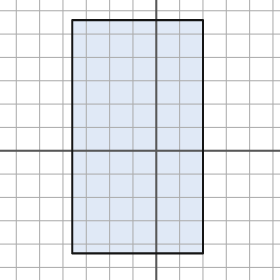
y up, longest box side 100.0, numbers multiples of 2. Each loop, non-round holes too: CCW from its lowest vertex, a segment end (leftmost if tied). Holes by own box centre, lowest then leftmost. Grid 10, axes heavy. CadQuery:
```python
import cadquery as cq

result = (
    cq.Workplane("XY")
    .moveTo(-36.0, -44.0)
    .lineTo(20.0, -44.0)
    .lineTo(20.0, 56.0)
    .lineTo(-36.0, 56.0)
    .close()
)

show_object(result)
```